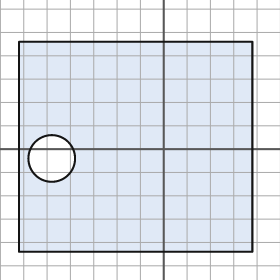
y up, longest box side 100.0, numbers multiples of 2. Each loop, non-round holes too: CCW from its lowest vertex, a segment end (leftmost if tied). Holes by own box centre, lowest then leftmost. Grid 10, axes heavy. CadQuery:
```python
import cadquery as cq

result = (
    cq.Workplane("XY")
    .moveTo(-62.0, -44.0)
    .lineTo(38.0, -44.0)
    .lineTo(38.0, 46.0)
    .lineTo(-62.0, 46.0)
    .close()
    .moveTo(-48.0, -4.0)
    .circle(10.0)
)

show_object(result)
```